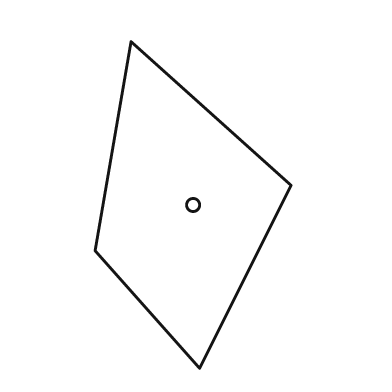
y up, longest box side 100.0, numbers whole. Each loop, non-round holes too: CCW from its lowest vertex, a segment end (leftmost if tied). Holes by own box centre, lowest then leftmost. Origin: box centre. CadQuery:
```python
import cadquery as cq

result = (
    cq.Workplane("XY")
    .moveTo(2.0, -50.0)
    .lineTo(30.0, 6.0)
    .lineTo(-19.0, 50.0)
    .lineTo(-30.0, -14.0)
    .close()
    .moveTo(0.0, 0.0)
    .circle(2.0)
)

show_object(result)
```